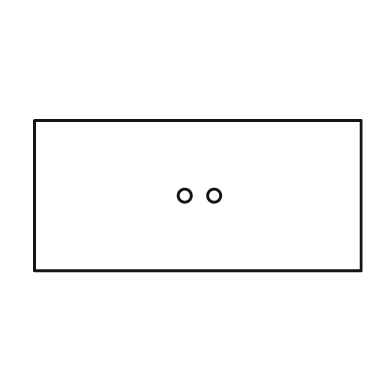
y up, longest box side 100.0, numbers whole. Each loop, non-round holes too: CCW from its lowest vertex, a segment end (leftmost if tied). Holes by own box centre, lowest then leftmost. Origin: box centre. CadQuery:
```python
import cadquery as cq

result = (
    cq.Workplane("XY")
    .moveTo(-50.0, -23.0)
    .lineTo(50.0, -23.0)
    .lineTo(50.0, 23.0)
    .lineTo(-50.0, 23.0)
    .close()
    .moveTo(-4.0, 0.0)
    .circle(2.0)
    .moveTo(5.0, 0.0)
    .circle(2.0)
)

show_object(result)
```